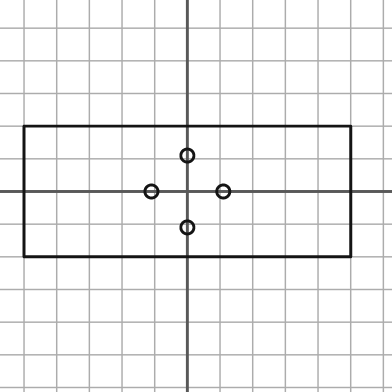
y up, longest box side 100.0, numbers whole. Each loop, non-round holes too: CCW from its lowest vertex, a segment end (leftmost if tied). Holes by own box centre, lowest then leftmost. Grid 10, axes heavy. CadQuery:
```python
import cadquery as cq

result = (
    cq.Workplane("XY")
    .moveTo(-50.0, -20.0)
    .lineTo(50.0, -20.0)
    .lineTo(50.0, 20.0)
    .lineTo(-50.0, 20.0)
    .close()
    .moveTo(0.0, -11.0)
    .circle(2.0)
    .moveTo(-11.0, 0.0)
    .circle(2.0)
    .moveTo(11.0, 0.0)
    .circle(2.0)
    .moveTo(0.0, 11.0)
    .circle(2.0)
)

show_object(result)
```